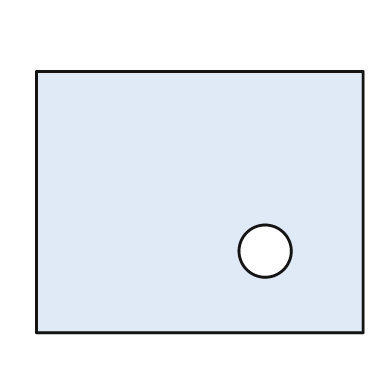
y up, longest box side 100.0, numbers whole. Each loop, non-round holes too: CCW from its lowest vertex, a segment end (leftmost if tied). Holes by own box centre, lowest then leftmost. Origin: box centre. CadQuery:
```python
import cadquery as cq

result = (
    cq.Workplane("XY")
    .moveTo(-50.0, -40.0)
    .lineTo(50.0, -40.0)
    .lineTo(50.0, 40.0)
    .lineTo(-50.0, 40.0)
    .close()
    .moveTo(20.0, -15.0)
    .circle(8.0)
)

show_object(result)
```